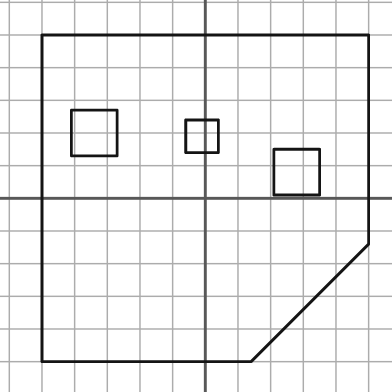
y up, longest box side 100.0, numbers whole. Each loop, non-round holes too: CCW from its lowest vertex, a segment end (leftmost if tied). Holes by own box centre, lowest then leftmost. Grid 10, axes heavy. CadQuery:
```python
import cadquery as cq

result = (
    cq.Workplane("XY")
    .moveTo(-50.0, -50.0)
    .lineTo(14.0, -50.0)
    .lineTo(50.0, -14.0)
    .lineTo(50.0, 50.0)
    .lineTo(-50.0, 50.0)
    .close()
    .moveTo(21.0, 1.0)
    .lineTo(35.0, 1.0)
    .lineTo(35.0, 15.0)
    .lineTo(21.0, 15.0)
    .close()
    .moveTo(-6.0, 14.0)
    .lineTo(4.0, 14.0)
    .lineTo(4.0, 24.0)
    .lineTo(-6.0, 24.0)
    .close()
    .moveTo(-41.0, 13.0)
    .lineTo(-27.0, 13.0)
    .lineTo(-27.0, 27.0)
    .lineTo(-41.0, 27.0)
    .close()
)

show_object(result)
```